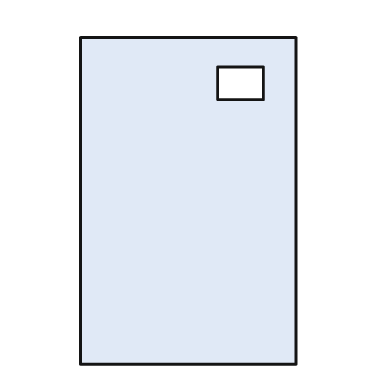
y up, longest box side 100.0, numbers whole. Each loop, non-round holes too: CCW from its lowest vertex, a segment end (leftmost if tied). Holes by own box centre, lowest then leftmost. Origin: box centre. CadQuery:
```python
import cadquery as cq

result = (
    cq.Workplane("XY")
    .moveTo(-33.0, -50.0)
    .lineTo(33.0, -50.0)
    .lineTo(33.0, 50.0)
    .lineTo(-33.0, 50.0)
    .close()
    .moveTo(9.0, 31.0)
    .lineTo(23.0, 31.0)
    .lineTo(23.0, 41.0)
    .lineTo(9.0, 41.0)
    .close()
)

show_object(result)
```